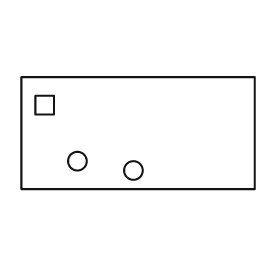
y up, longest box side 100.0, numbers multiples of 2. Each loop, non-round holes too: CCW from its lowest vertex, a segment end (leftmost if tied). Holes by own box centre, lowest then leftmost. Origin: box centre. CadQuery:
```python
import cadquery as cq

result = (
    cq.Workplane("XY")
    .moveTo(-50.0, -24.0)
    .lineTo(50.0, -24.0)
    .lineTo(50.0, 24.0)
    .lineTo(-50.0, 24.0)
    .close()
    .moveTo(-2.0, -16.0)
    .circle(4.0)
    .moveTo(-26.0, -12.0)
    .circle(4.0)
    .moveTo(-44.0, 8.0)
    .lineTo(-36.0, 8.0)
    .lineTo(-36.0, 16.0)
    .lineTo(-44.0, 16.0)
    .close()
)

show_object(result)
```